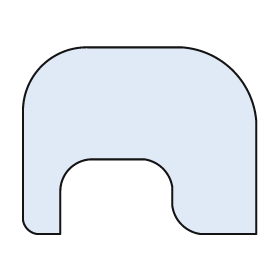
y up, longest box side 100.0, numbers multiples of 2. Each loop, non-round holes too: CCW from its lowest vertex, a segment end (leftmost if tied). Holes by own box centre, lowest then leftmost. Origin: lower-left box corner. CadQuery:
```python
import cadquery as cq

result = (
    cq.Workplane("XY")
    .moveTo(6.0, 0.0)
    .lineTo(16.0, 0.0)
    .lineTo(16.0, 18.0)
    .threePointArc((20.0, 28.0), (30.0, 32.0))
    .lineTo(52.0, 32.0)
    .threePointArc((60.0, 28.0), (64.0, 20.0))
    .lineTo(64.0, 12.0)
    .threePointArc((68.0, 4.0), (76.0, 0.0))
    .lineTo(100.0, 0.0)
    .lineTo(100.0, 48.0)
    .threePointArc((90.0, 70.0), (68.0, 80.0))
    .lineTo(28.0, 80.0)
    .threePointArc((8.0, 72.0), (0.0, 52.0))
    .lineTo(0.0, 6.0)
    .threePointArc((2.0, 2.0), (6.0, 0.0))
    .close()
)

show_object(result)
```